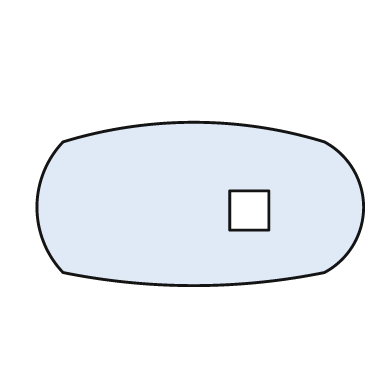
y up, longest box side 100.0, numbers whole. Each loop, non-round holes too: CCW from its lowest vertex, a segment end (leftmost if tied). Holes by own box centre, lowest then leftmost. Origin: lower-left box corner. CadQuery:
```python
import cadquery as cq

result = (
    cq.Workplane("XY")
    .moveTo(8.0, 4.0)
    .threePointArc((48.0, 0.0), (88.0, 4.0))
    .threePointArc((100.0, 24.0), (88.0, 44.0))
    .threePointArc((48.0, 50.0), (8.0, 44.0))
    .threePointArc((0.0, 24.0), (8.0, 4.0))
    .close()
    .moveTo(59.0, 17.0)
    .lineTo(71.0, 17.0)
    .lineTo(71.0, 29.0)
    .lineTo(59.0, 29.0)
    .close()
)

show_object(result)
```